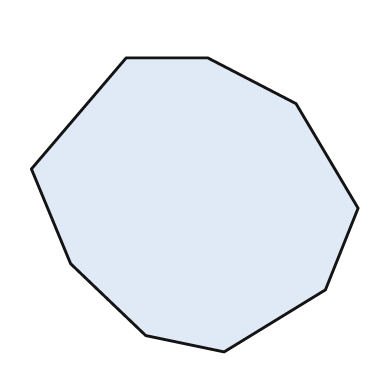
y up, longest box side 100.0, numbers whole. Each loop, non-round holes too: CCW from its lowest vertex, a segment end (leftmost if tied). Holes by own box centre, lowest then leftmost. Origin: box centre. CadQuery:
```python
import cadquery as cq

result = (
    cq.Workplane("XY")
    .moveTo(9.0, -45.0)
    .lineTo(40.0, -26.0)
    .lineTo(50.0, -1.0)
    .lineTo(31.0, 31.0)
    .lineTo(4.0, 45.0)
    .lineTo(-21.0, 45.0)
    .lineTo(-50.0, 11.0)
    .lineTo(-38.0, -18.0)
    .lineTo(-15.0, -40.0)
    .close()
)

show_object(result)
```